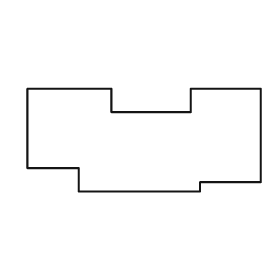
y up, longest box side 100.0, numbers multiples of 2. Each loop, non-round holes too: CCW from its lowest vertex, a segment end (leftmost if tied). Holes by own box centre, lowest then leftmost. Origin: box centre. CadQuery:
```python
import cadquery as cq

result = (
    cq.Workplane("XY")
    .moveTo(-28.0, -22.0)
    .lineTo(24.0, -22.0)
    .lineTo(24.0, -18.0)
    .lineTo(50.0, -18.0)
    .lineTo(50.0, 22.0)
    .lineTo(20.0, 22.0)
    .lineTo(20.0, 12.0)
    .lineTo(-14.0, 12.0)
    .lineTo(-14.0, 22.0)
    .lineTo(-50.0, 22.0)
    .lineTo(-50.0, -12.0)
    .lineTo(-28.0, -12.0)
    .close()
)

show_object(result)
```